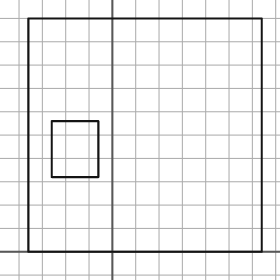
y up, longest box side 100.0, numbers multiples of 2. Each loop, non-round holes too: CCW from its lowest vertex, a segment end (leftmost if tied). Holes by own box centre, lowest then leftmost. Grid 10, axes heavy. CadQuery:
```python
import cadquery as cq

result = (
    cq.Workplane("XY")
    .moveTo(-36.0, 0.0)
    .lineTo(64.0, 0.0)
    .lineTo(64.0, 100.0)
    .lineTo(-36.0, 100.0)
    .close()
    .moveTo(-26.0, 32.0)
    .lineTo(-6.0, 32.0)
    .lineTo(-6.0, 56.0)
    .lineTo(-26.0, 56.0)
    .close()
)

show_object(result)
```